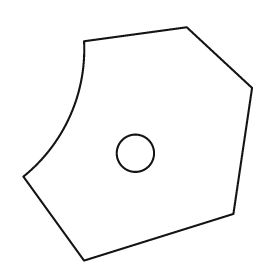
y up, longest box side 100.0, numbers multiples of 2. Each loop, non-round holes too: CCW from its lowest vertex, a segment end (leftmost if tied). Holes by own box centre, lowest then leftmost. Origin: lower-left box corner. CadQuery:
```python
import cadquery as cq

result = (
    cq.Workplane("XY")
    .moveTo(26.0, 0.0)
    .lineTo(90.0, 20.0)
    .lineTo(98.0, 74.0)
    .lineTo(70.0, 100.0)
    .lineTo(26.0, 94.0)
    .threePointArc((20.0, 62.0), (0.0, 36.0))
    .close()
    .moveTo(48.0, 46.0)
    .circle(8.0)
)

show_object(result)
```